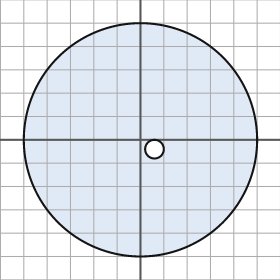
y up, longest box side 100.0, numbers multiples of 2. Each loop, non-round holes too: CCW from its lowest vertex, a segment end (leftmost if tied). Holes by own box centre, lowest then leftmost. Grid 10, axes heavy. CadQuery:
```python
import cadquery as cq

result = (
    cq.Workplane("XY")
    .moveTo(0.0, 0.0)
    .circle(50.0)
    .moveTo(6.0, -4.0)
    .circle(4.0)
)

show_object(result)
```